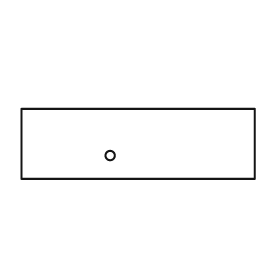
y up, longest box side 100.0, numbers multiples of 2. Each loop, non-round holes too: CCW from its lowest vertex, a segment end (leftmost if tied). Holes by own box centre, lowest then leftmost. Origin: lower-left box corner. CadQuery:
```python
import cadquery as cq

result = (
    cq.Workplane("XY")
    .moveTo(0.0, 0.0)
    .lineTo(100.0, 0.0)
    .lineTo(100.0, 30.0)
    .lineTo(0.0, 30.0)
    .close()
    .moveTo(38.0, 10.0)
    .circle(2.0)
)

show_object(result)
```